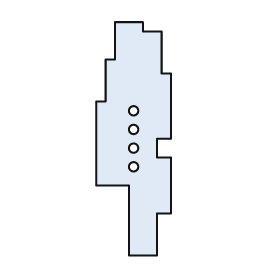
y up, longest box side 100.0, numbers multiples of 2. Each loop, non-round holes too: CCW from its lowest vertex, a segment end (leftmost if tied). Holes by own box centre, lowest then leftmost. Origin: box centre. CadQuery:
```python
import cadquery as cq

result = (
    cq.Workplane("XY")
    .moveTo(-2.0, -50.0)
    .lineTo(10.0, -50.0)
    .lineTo(10.0, -32.0)
    .lineTo(16.0, -32.0)
    .lineTo(16.0, -8.0)
    .lineTo(10.0, -8.0)
    .lineTo(10.0, 0.0)
    .lineTo(16.0, 0.0)
    .lineTo(16.0, 28.0)
    .lineTo(12.0, 28.0)
    .lineTo(12.0, 46.0)
    .lineTo(4.0, 46.0)
    .lineTo(4.0, 50.0)
    .lineTo(-8.0, 50.0)
    .lineTo(-8.0, 34.0)
    .lineTo(-12.0, 34.0)
    .lineTo(-12.0, 16.0)
    .lineTo(-16.0, 16.0)
    .lineTo(-16.0, -20.0)
    .lineTo(-2.0, -20.0)
    .close()
    .moveTo(0.0, -12.0)
    .circle(2.0)
    .moveTo(0.0, -4.0)
    .circle(2.0)
    .moveTo(0.0, 4.0)
    .circle(2.0)
    .moveTo(0.0, 12.0)
    .circle(2.0)
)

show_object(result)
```